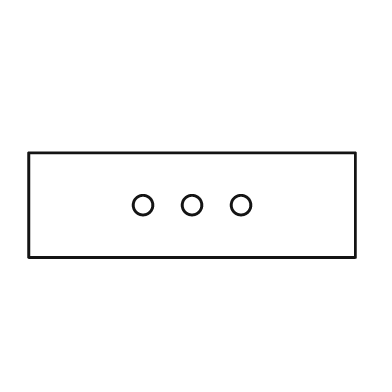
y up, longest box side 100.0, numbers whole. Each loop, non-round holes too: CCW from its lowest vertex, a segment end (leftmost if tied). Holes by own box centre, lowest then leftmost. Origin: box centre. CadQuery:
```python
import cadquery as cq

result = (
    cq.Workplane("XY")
    .moveTo(-50.0, -16.0)
    .lineTo(50.0, -16.0)
    .lineTo(50.0, 16.0)
    .lineTo(-50.0, 16.0)
    .close()
    .moveTo(-15.0, 0.0)
    .circle(3.0)
    .moveTo(0.0, 0.0)
    .circle(3.0)
    .moveTo(15.0, 0.0)
    .circle(3.0)
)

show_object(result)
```